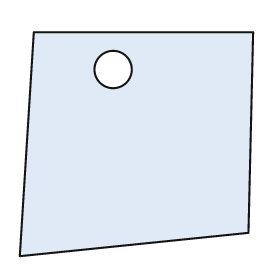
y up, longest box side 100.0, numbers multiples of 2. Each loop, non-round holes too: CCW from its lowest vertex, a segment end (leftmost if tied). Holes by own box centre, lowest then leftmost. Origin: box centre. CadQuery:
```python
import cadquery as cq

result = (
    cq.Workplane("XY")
    .moveTo(-50.0, -48.0)
    .lineTo(48.0, -38.0)
    .lineTo(50.0, 48.0)
    .lineTo(-44.0, 48.0)
    .close()
    .moveTo(-10.0, 32.0)
    .circle(8.0)
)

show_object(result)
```